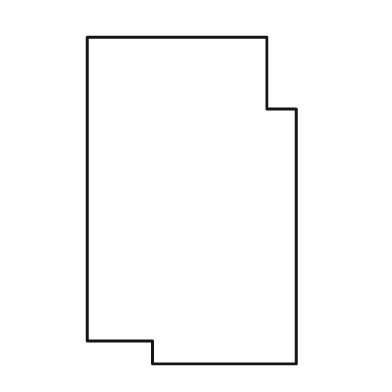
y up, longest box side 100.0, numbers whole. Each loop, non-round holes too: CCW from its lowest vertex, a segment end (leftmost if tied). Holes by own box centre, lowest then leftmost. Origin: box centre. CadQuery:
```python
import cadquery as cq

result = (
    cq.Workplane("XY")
    .moveTo(-12.0, -50.0)
    .lineTo(32.0, -50.0)
    .lineTo(32.0, 28.0)
    .lineTo(23.0, 28.0)
    .lineTo(23.0, 50.0)
    .lineTo(-32.0, 50.0)
    .lineTo(-32.0, -43.0)
    .lineTo(-12.0, -43.0)
    .close()
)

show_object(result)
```